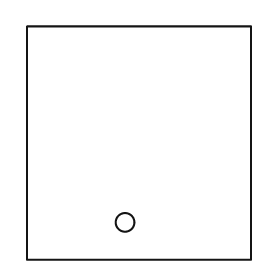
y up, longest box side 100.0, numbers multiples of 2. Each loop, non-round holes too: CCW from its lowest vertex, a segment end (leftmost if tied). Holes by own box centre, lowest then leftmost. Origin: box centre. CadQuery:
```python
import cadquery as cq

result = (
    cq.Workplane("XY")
    .moveTo(-48.0, -50.0)
    .lineTo(48.0, -50.0)
    .lineTo(48.0, 50.0)
    .lineTo(-48.0, 50.0)
    .close()
    .moveTo(-6.0, -34.0)
    .circle(4.0)
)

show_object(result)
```